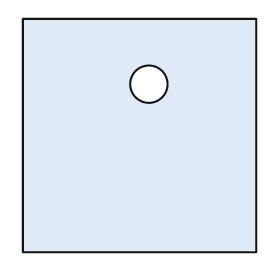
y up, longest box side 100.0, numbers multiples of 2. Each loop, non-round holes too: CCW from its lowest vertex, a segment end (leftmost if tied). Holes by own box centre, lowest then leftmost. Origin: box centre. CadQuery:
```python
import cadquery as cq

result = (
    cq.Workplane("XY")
    .moveTo(-50.0, -50.0)
    .lineTo(50.0, -50.0)
    .lineTo(50.0, 50.0)
    .lineTo(-50.0, 50.0)
    .close()
    .moveTo(4.0, 22.0)
    .circle(8.0)
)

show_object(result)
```